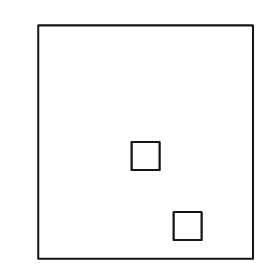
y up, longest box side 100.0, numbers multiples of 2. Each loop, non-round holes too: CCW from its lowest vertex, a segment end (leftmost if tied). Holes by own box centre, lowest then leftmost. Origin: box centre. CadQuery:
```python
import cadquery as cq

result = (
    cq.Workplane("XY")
    .moveTo(-46.0, -50.0)
    .lineTo(46.0, -50.0)
    .lineTo(46.0, 50.0)
    .lineTo(-46.0, 50.0)
    .close()
    .moveTo(12.0, -42.0)
    .lineTo(24.0, -42.0)
    .lineTo(24.0, -30.0)
    .lineTo(12.0, -30.0)
    .close()
    .moveTo(-6.0, -12.0)
    .lineTo(6.0, -12.0)
    .lineTo(6.0, 0.0)
    .lineTo(-6.0, 0.0)
    .close()
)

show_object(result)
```